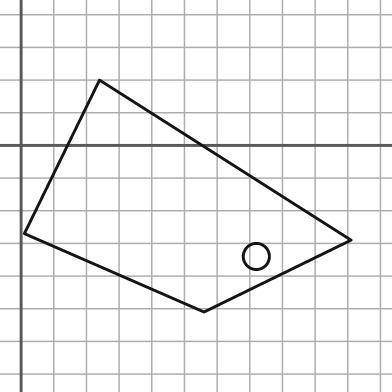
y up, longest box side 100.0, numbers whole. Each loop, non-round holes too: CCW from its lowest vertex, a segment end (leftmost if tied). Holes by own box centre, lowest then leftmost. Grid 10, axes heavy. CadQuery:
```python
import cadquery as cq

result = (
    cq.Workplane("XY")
    .moveTo(56.0, -51.0)
    .lineTo(101.0, -29.0)
    .lineTo(24.0, 20.0)
    .lineTo(1.0, -27.0)
    .close()
    .moveTo(72.0, -34.0)
    .circle(4.0)
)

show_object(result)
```